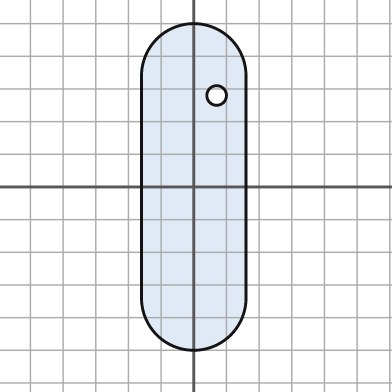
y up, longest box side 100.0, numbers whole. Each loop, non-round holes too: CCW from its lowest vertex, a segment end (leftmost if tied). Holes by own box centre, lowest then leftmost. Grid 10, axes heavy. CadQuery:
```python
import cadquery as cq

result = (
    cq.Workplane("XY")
    .moveTo(-16.0, -34.0)
    .threePointArc((0.0, -50.0), (16.0, -34.0))
    .lineTo(16.0, 34.0)
    .threePointArc((0.0, 50.0), (-16.0, 34.0))
    .close()
    .moveTo(7.0, 28.0)
    .circle(3.0)
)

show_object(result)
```